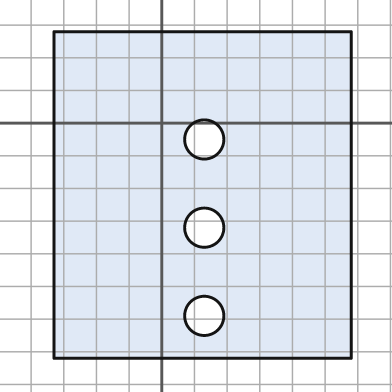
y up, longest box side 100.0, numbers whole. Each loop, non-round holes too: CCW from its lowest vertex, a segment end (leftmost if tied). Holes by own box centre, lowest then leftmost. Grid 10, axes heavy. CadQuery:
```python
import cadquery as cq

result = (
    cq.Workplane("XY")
    .moveTo(-33.0, -72.0)
    .lineTo(58.0, -72.0)
    .lineTo(58.0, 28.0)
    .lineTo(-33.0, 28.0)
    .close()
    .moveTo(13.0, -59.0)
    .circle(6.0)
    .moveTo(13.0, -32.0)
    .circle(6.0)
    .moveTo(13.0, -5.0)
    .circle(6.0)
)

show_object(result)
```